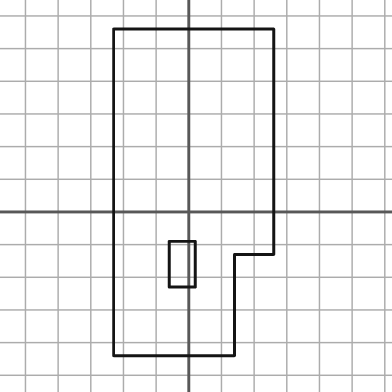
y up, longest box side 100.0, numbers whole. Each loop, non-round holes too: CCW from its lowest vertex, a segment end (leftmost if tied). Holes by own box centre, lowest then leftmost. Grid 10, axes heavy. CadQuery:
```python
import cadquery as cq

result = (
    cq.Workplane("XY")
    .moveTo(-23.0, -44.0)
    .lineTo(14.0, -44.0)
    .lineTo(14.0, -13.0)
    .lineTo(26.0, -13.0)
    .lineTo(26.0, 56.0)
    .lineTo(-23.0, 56.0)
    .close()
    .moveTo(-6.0, -23.0)
    .lineTo(2.0, -23.0)
    .lineTo(2.0, -9.0)
    .lineTo(-6.0, -9.0)
    .close()
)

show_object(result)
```